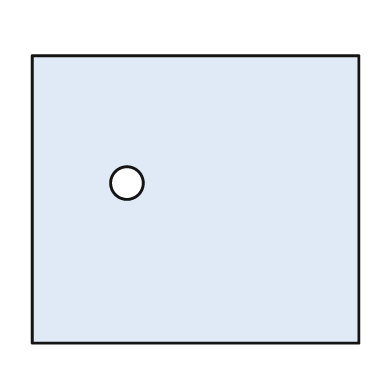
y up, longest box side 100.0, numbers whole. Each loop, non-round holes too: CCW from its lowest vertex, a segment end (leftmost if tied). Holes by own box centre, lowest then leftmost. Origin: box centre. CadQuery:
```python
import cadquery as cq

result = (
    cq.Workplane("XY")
    .moveTo(-50.0, -44.0)
    .lineTo(50.0, -44.0)
    .lineTo(50.0, 44.0)
    .lineTo(-50.0, 44.0)
    .close()
    .moveTo(-21.0, 5.0)
    .circle(5.0)
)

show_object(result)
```